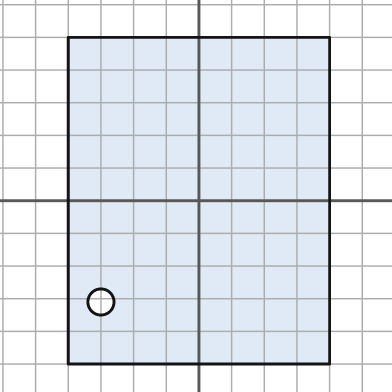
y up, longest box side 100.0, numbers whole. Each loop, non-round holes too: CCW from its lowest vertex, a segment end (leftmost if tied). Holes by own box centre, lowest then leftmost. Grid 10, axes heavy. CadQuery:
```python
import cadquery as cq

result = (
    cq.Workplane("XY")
    .moveTo(-40.0, -50.0)
    .lineTo(40.0, -50.0)
    .lineTo(40.0, 50.0)
    .lineTo(-40.0, 50.0)
    .close()
    .moveTo(-30.0, -31.0)
    .circle(4.0)
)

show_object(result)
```